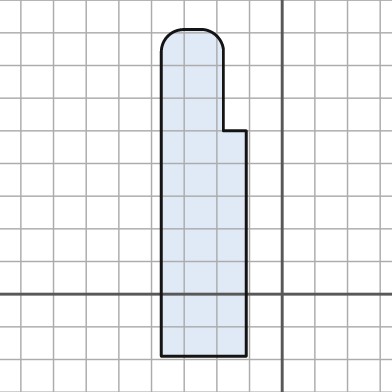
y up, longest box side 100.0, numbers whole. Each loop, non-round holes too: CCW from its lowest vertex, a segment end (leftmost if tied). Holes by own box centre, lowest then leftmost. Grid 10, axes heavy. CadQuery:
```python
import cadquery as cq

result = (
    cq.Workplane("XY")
    .moveTo(-37.0, -19.0)
    .lineTo(-11.0, -19.0)
    .lineTo(-11.0, 50.0)
    .lineTo(-18.0, 50.0)
    .lineTo(-18.0, 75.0)
    .threePointArc((-20.0, 79.0), (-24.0, 81.0))
    .lineTo(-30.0, 81.0)
    .threePointArc((-35.0, 79.0), (-37.0, 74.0))
    .close()
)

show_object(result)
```